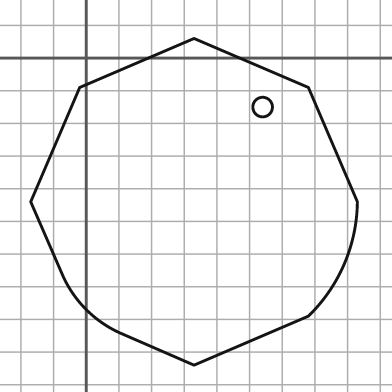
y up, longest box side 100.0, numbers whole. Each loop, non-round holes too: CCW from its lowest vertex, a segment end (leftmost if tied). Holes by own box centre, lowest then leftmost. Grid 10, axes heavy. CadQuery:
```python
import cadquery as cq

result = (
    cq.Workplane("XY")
    .moveTo(33.0, -94.0)
    .lineTo(68.0, -79.0)
    .threePointArc((79.0, -63.0), (83.0, -44.0))
    .lineTo(68.0, -9.0)
    .lineTo(33.0, 6.0)
    .lineTo(-2.0, -9.0)
    .lineTo(-17.0, -44.0)
    .lineTo(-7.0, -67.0)
    .threePointArc((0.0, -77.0), (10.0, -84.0))
    .close()
    .moveTo(54.0, -15.0)
    .circle(3.0)
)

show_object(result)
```